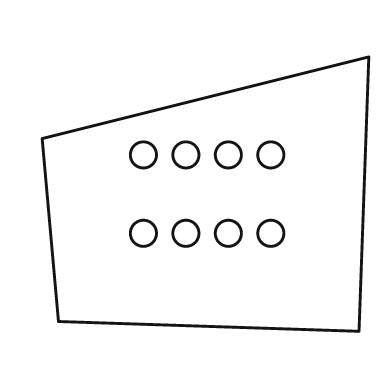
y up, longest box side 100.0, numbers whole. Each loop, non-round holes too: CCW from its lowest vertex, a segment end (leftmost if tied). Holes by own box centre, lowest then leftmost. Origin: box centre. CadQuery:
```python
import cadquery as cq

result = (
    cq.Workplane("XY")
    .moveTo(47.0, -42.0)
    .lineTo(50.0, 42.0)
    .lineTo(-50.0, 17.0)
    .lineTo(-45.0, -39.0)
    .close()
    .moveTo(-19.0, -12.0)
    .circle(4.0)
    .moveTo(-6.0, -12.0)
    .circle(4.0)
    .moveTo(7.0, -12.0)
    .circle(4.0)
    .moveTo(20.0, -12.0)
    .circle(4.0)
    .moveTo(-19.0, 12.0)
    .circle(4.0)
    .moveTo(-6.0, 12.0)
    .circle(4.0)
    .moveTo(7.0, 12.0)
    .circle(4.0)
    .moveTo(20.0, 12.0)
    .circle(4.0)
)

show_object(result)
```